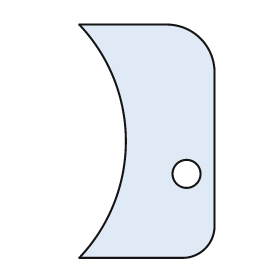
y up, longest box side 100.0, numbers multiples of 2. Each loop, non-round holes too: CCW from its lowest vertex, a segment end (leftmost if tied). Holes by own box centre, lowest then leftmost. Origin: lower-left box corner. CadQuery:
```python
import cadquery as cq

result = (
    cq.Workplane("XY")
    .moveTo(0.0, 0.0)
    .lineTo(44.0, 0.0)
    .threePointArc((54.0, 4.0), (58.0, 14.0))
    .lineTo(58.0, 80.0)
    .threePointArc((52.0, 94.0), (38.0, 100.0))
    .lineTo(0.0, 100.0)
    .threePointArc((20.0, 50.0), (0.0, 0.0))
    .close()
    .moveTo(46.0, 36.0)
    .circle(6.0)
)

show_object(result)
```